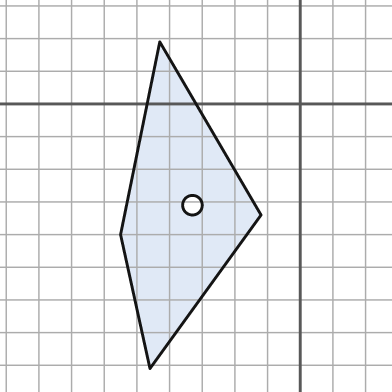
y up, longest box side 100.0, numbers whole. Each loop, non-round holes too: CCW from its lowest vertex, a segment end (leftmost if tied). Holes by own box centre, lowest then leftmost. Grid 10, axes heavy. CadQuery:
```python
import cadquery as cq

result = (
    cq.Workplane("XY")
    .moveTo(-46.0, -81.0)
    .lineTo(-12.0, -34.0)
    .lineTo(-43.0, 19.0)
    .lineTo(-55.0, -40.0)
    .close()
    .moveTo(-33.0, -31.0)
    .circle(3.0)
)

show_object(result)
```